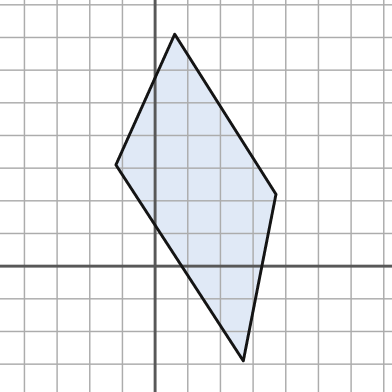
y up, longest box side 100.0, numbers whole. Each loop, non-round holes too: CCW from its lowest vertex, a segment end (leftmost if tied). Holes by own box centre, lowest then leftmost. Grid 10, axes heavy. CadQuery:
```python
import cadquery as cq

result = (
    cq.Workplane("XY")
    .moveTo(27.0, -29.0)
    .lineTo(37.0, 22.0)
    .lineTo(6.0, 71.0)
    .lineTo(-12.0, 31.0)
    .close()
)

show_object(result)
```